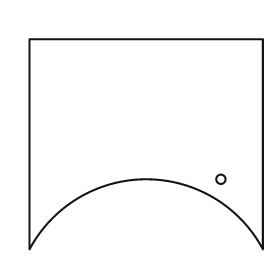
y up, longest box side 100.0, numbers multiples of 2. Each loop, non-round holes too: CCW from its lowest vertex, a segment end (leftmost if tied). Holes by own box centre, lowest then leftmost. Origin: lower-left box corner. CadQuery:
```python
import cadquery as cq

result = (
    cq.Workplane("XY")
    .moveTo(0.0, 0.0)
    .threePointArc((50.0, 30.0), (100.0, 0.0))
    .lineTo(100.0, 90.0)
    .lineTo(0.0, 90.0)
    .close()
    .moveTo(82.0, 30.0)
    .circle(2.0)
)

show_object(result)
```